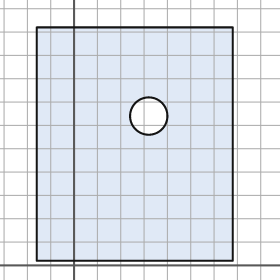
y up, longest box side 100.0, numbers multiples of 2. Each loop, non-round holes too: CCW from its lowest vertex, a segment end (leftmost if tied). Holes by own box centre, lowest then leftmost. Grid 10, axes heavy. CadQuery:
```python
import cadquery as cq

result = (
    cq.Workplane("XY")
    .moveTo(-16.0, 2.0)
    .lineTo(68.0, 2.0)
    .lineTo(68.0, 102.0)
    .lineTo(-16.0, 102.0)
    .close()
    .moveTo(32.0, 64.0)
    .circle(8.0)
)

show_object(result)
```